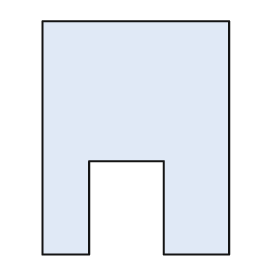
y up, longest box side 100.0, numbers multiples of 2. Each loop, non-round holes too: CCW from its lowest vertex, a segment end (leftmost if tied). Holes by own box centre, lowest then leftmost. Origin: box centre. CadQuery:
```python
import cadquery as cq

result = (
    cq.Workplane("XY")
    .moveTo(-40.0, -50.0)
    .lineTo(-20.0, -50.0)
    .lineTo(-20.0, -10.0)
    .lineTo(12.0, -10.0)
    .lineTo(12.0, -50.0)
    .lineTo(40.0, -50.0)
    .lineTo(40.0, 50.0)
    .lineTo(-40.0, 50.0)
    .close()
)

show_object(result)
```